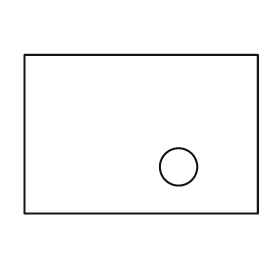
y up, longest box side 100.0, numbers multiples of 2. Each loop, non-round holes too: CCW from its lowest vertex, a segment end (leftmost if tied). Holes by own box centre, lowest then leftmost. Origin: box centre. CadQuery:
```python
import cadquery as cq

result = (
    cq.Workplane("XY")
    .moveTo(-50.0, -34.0)
    .lineTo(50.0, -34.0)
    .lineTo(50.0, 34.0)
    .lineTo(-50.0, 34.0)
    .close()
    .moveTo(16.0, -14.0)
    .circle(8.0)
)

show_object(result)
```